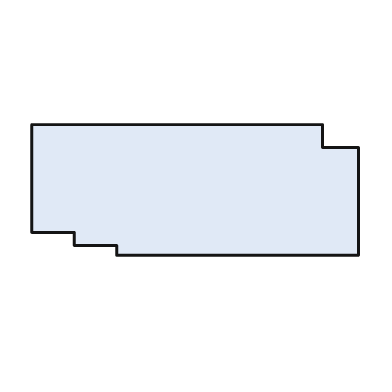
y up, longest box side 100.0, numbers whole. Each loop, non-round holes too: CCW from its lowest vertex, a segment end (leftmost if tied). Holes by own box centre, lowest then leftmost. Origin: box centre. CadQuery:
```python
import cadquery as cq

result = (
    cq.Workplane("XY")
    .moveTo(-24.0, -20.0)
    .lineTo(50.0, -20.0)
    .lineTo(50.0, 13.0)
    .lineTo(39.0, 13.0)
    .lineTo(39.0, 20.0)
    .lineTo(-50.0, 20.0)
    .lineTo(-50.0, -13.0)
    .lineTo(-37.0, -13.0)
    .lineTo(-37.0, -17.0)
    .lineTo(-24.0, -17.0)
    .close()
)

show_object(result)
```